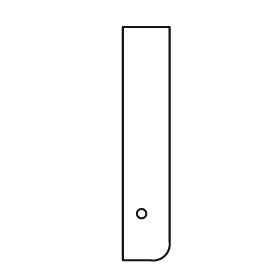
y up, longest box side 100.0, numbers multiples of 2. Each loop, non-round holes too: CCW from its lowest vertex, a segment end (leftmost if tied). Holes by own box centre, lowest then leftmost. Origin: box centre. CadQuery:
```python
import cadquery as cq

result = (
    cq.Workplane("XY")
    .moveTo(-10.0, -50.0)
    .lineTo(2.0, -50.0)
    .threePointArc((8.0, -48.0), (10.0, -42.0))
    .lineTo(10.0, 50.0)
    .lineTo(-10.0, 50.0)
    .close()
    .moveTo(-2.0, -30.0)
    .circle(2.0)
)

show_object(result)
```